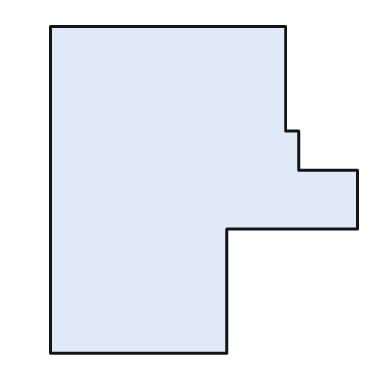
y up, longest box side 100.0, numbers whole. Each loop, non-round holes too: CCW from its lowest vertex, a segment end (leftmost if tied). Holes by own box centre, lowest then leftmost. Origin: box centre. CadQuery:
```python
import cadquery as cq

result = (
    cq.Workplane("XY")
    .moveTo(-47.0, -50.0)
    .lineTo(7.0, -50.0)
    .lineTo(7.0, -12.0)
    .lineTo(47.0, -12.0)
    .lineTo(47.0, 6.0)
    .lineTo(29.0, 6.0)
    .lineTo(29.0, 18.0)
    .lineTo(25.0, 18.0)
    .lineTo(25.0, 50.0)
    .lineTo(-47.0, 50.0)
    .close()
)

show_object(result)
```